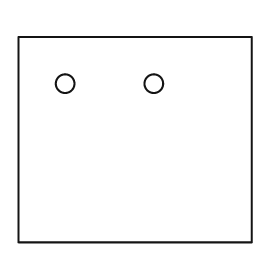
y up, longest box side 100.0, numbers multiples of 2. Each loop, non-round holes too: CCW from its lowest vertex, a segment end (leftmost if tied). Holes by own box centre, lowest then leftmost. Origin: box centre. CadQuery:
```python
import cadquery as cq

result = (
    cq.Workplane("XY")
    .moveTo(-50.0, -44.0)
    .lineTo(50.0, -44.0)
    .lineTo(50.0, 44.0)
    .lineTo(-50.0, 44.0)
    .close()
    .moveTo(-30.0, 24.0)
    .circle(4.0)
    .moveTo(8.0, 24.0)
    .circle(4.0)
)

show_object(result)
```